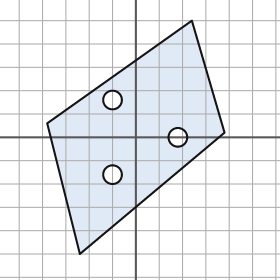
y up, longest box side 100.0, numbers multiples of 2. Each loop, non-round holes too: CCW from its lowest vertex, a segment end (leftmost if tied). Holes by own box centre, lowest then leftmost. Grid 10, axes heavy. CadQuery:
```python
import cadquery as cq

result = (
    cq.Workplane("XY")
    .moveTo(-24.0, -50.0)
    .lineTo(38.0, 2.0)
    .lineTo(24.0, 50.0)
    .lineTo(-38.0, 6.0)
    .close()
    .moveTo(-10.0, -16.0)
    .circle(4.0)
    .moveTo(18.0, 0.0)
    .circle(4.0)
    .moveTo(-10.0, 16.0)
    .circle(4.0)
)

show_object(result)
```